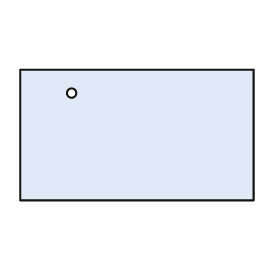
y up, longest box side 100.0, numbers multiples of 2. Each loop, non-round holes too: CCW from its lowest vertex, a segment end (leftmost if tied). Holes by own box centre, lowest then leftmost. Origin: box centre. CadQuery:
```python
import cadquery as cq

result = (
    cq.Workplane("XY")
    .moveTo(-50.0, -28.0)
    .lineTo(50.0, -28.0)
    .lineTo(50.0, 28.0)
    .lineTo(-50.0, 28.0)
    .close()
    .moveTo(-28.0, 18.0)
    .circle(2.0)
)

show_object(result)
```